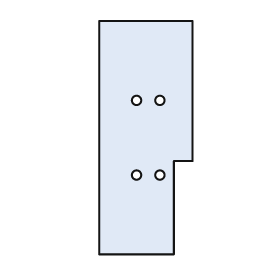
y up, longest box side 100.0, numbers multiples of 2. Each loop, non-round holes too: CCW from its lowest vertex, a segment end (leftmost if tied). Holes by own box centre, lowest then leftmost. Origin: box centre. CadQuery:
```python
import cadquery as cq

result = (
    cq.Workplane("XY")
    .moveTo(-20.0, -50.0)
    .lineTo(12.0, -50.0)
    .lineTo(12.0, -10.0)
    .lineTo(20.0, -10.0)
    .lineTo(20.0, 50.0)
    .lineTo(-20.0, 50.0)
    .close()
    .moveTo(-4.0, -16.0)
    .circle(2.0)
    .moveTo(6.0, -16.0)
    .circle(2.0)
    .moveTo(-4.0, 16.0)
    .circle(2.0)
    .moveTo(6.0, 16.0)
    .circle(2.0)
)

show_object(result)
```